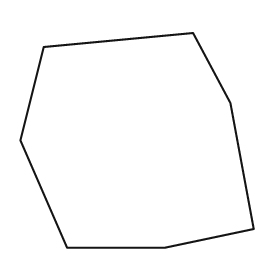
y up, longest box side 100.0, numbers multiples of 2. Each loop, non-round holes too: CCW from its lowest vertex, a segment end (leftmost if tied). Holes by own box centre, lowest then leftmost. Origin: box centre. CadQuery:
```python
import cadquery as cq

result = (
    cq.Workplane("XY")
    .moveTo(-30.0, -46.0)
    .lineTo(12.0, -46.0)
    .lineTo(50.0, -38.0)
    .lineTo(40.0, 16.0)
    .lineTo(24.0, 46.0)
    .lineTo(-40.0, 40.0)
    .lineTo(-50.0, 0.0)
    .close()
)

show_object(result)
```